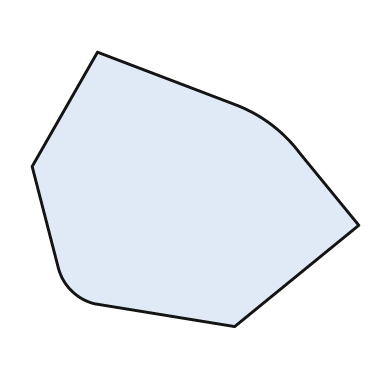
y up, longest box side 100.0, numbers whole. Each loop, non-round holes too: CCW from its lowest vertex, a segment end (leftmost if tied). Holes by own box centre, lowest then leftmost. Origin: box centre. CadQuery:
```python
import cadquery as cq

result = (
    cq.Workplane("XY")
    .moveTo(12.0, -42.0)
    .lineTo(50.0, -11.0)
    .lineTo(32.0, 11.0)
    .threePointArc((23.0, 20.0), (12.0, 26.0))
    .lineTo(-30.0, 42.0)
    .lineTo(-50.0, 7.0)
    .lineTo(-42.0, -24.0)
    .threePointArc((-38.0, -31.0), (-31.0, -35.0))
    .close()
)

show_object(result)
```